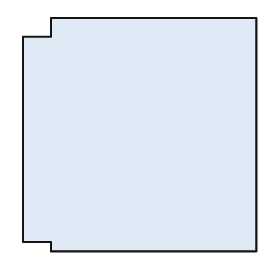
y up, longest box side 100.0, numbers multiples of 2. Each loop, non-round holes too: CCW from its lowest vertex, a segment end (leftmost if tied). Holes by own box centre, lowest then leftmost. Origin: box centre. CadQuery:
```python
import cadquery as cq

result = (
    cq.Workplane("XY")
    .moveTo(-38.0, -50.0)
    .lineTo(50.0, -50.0)
    .lineTo(50.0, 50.0)
    .lineTo(-38.0, 50.0)
    .lineTo(-38.0, 42.0)
    .lineTo(-50.0, 42.0)
    .lineTo(-50.0, -46.0)
    .lineTo(-38.0, -46.0)
    .close()
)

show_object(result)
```